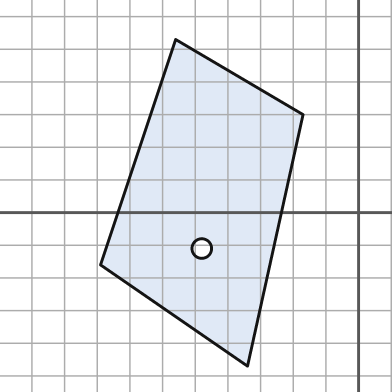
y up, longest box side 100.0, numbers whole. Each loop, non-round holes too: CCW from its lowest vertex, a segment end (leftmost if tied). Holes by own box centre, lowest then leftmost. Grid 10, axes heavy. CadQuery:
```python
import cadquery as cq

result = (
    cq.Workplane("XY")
    .moveTo(-34.0, -47.0)
    .lineTo(-17.0, 30.0)
    .lineTo(-56.0, 53.0)
    .lineTo(-79.0, -16.0)
    .close()
    .moveTo(-48.0, -11.0)
    .circle(3.0)
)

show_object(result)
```